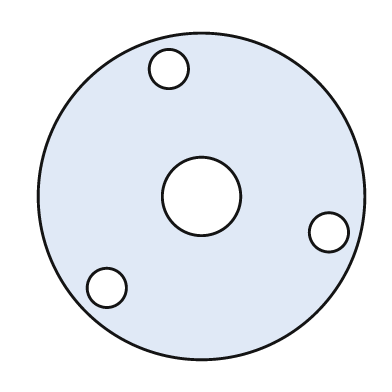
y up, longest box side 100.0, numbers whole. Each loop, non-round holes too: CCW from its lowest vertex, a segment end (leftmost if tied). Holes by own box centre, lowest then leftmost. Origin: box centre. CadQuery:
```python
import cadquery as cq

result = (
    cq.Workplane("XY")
    .moveTo(0.0, 0.0)
    .circle(50.0)
    .moveTo(-29.0, -28.0)
    .circle(6.0)
    .moveTo(39.0, -11.0)
    .circle(6.0)
    .moveTo(0.0, 0.0)
    .circle(12.0)
    .moveTo(-10.0, 39.0)
    .circle(6.0)
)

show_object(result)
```